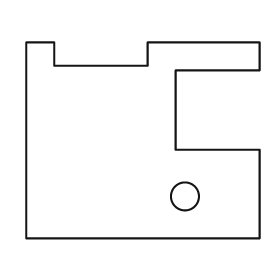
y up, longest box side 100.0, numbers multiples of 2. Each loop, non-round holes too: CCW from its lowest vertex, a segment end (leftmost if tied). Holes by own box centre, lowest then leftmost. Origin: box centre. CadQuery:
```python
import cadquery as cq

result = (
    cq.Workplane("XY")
    .moveTo(-50.0, -42.0)
    .lineTo(50.0, -42.0)
    .lineTo(50.0, -4.0)
    .lineTo(14.0, -4.0)
    .lineTo(14.0, 30.0)
    .lineTo(50.0, 30.0)
    .lineTo(50.0, 42.0)
    .lineTo(2.0, 42.0)
    .lineTo(2.0, 32.0)
    .lineTo(-38.0, 32.0)
    .lineTo(-38.0, 42.0)
    .lineTo(-50.0, 42.0)
    .close()
    .moveTo(18.0, -24.0)
    .circle(6.0)
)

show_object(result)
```